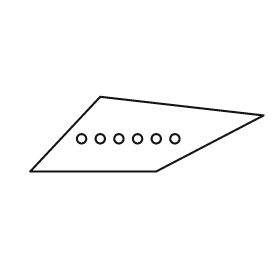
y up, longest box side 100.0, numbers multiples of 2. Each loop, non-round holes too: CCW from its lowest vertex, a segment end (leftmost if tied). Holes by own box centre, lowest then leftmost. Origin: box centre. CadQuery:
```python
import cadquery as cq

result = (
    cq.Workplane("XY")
    .moveTo(-50.0, -16.0)
    .lineTo(4.0, -16.0)
    .lineTo(50.0, 8.0)
    .lineTo(-20.0, 16.0)
    .close()
    .moveTo(-28.0, -2.0)
    .circle(2.0)
    .moveTo(-20.0, -2.0)
    .circle(2.0)
    .moveTo(-12.0, -2.0)
    .circle(2.0)
    .moveTo(-4.0, -2.0)
    .circle(2.0)
    .moveTo(4.0, -2.0)
    .circle(2.0)
    .moveTo(12.0, -2.0)
    .circle(2.0)
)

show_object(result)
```